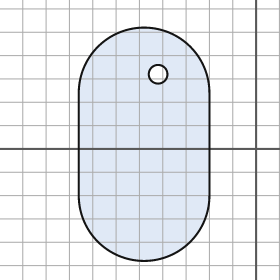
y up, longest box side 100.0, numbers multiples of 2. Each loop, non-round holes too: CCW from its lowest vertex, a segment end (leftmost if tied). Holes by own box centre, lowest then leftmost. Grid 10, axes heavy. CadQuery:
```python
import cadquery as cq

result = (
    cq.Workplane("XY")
    .moveTo(-76.0, -20.0)
    .threePointArc((-48.0, -48.0), (-20.0, -20.0))
    .lineTo(-20.0, 24.0)
    .threePointArc((-48.0, 52.0), (-76.0, 24.0))
    .close()
    .moveTo(-42.0, 32.0)
    .circle(4.0)
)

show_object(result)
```